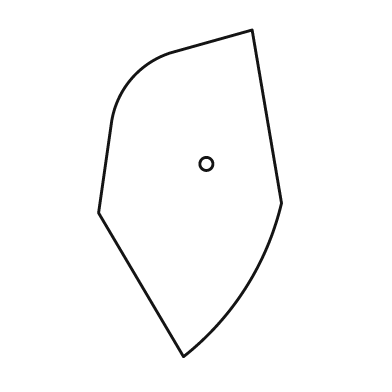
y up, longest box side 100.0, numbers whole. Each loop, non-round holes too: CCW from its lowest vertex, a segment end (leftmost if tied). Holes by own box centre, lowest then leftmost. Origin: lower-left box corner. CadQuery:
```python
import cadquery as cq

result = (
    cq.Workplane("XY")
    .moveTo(26.0, 0.0)
    .threePointArc((45.0, 21.0), (56.0, 47.0))
    .lineTo(47.0, 100.0)
    .lineTo(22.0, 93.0)
    .threePointArc((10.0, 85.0), (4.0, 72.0))
    .lineTo(0.0, 44.0)
    .close()
    .moveTo(33.0, 59.0)
    .circle(2.0)
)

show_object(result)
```